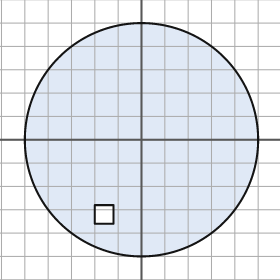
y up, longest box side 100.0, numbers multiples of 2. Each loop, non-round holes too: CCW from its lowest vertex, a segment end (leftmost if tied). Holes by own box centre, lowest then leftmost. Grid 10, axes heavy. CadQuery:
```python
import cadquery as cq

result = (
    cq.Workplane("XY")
    .moveTo(0.0, 0.0)
    .circle(50.0)
    .moveTo(-20.0, -36.0)
    .lineTo(-12.0, -36.0)
    .lineTo(-12.0, -28.0)
    .lineTo(-20.0, -28.0)
    .close()
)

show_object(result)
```